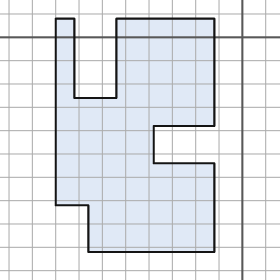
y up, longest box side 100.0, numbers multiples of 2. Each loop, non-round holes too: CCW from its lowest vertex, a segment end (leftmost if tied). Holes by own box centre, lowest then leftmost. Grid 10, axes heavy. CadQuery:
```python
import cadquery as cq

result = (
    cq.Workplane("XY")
    .moveTo(-66.0, -92.0)
    .lineTo(-12.0, -92.0)
    .lineTo(-12.0, -54.0)
    .lineTo(-38.0, -54.0)
    .lineTo(-38.0, -38.0)
    .lineTo(-12.0, -38.0)
    .lineTo(-12.0, 8.0)
    .lineTo(-54.0, 8.0)
    .lineTo(-54.0, -26.0)
    .lineTo(-72.0, -26.0)
    .lineTo(-72.0, 8.0)
    .lineTo(-80.0, 8.0)
    .lineTo(-80.0, -72.0)
    .lineTo(-66.0, -72.0)
    .close()
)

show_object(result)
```